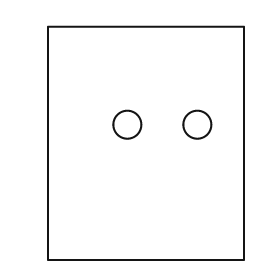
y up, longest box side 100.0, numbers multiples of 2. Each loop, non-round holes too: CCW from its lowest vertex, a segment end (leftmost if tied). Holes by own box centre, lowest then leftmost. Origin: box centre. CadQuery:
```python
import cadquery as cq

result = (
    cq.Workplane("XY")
    .moveTo(-42.0, -50.0)
    .lineTo(42.0, -50.0)
    .lineTo(42.0, 50.0)
    .lineTo(-42.0, 50.0)
    .close()
    .moveTo(-8.0, 8.0)
    .circle(6.0)
    .moveTo(22.0, 8.0)
    .circle(6.0)
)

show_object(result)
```